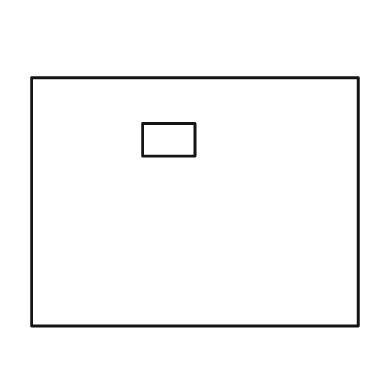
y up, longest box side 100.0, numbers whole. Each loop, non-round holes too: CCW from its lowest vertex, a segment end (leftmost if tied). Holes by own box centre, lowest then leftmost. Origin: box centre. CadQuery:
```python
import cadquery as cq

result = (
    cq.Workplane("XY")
    .moveTo(-50.0, -38.0)
    .lineTo(50.0, -38.0)
    .lineTo(50.0, 38.0)
    .lineTo(-50.0, 38.0)
    .close()
    .moveTo(-16.0, 14.0)
    .lineTo(0.0, 14.0)
    .lineTo(0.0, 24.0)
    .lineTo(-16.0, 24.0)
    .close()
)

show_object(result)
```